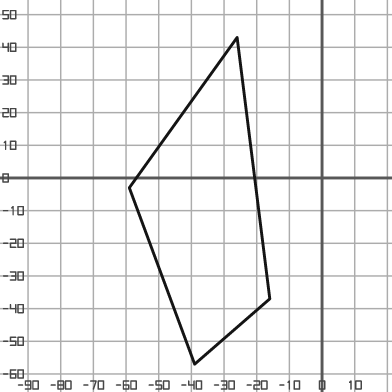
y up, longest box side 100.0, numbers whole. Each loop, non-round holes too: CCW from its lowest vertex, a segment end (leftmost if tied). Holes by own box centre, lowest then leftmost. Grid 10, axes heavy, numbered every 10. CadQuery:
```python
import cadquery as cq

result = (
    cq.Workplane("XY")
    .moveTo(-39.0, -57.0)
    .lineTo(-16.0, -37.0)
    .lineTo(-26.0, 43.0)
    .lineTo(-59.0, -3.0)
    .close()
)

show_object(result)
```